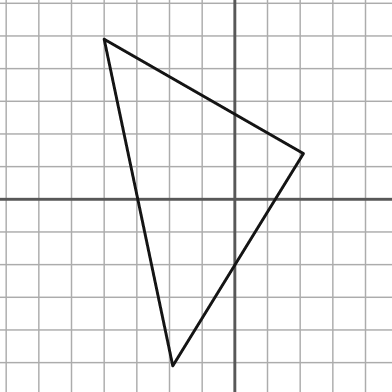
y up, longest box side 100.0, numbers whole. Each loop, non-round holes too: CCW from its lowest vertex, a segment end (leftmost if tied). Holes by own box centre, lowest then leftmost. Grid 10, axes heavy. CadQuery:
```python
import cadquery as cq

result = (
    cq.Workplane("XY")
    .moveTo(-19.0, -51.0)
    .lineTo(21.0, 14.0)
    .lineTo(-40.0, 49.0)
    .close()
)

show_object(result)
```